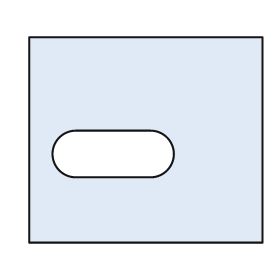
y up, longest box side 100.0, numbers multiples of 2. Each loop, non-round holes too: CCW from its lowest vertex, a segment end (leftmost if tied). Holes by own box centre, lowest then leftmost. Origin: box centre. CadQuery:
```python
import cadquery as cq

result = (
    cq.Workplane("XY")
    .moveTo(-50.0, -44.0)
    .lineTo(50.0, -44.0)
    .lineTo(50.0, 44.0)
    .lineTo(-50.0, 44.0)
    .close()
    .moveTo(-30.0, -16.0)
    .lineTo(2.0, -16.0)
    .threePointArc((12.0, -6.0), (2.0, 4.0))
    .lineTo(-30.0, 4.0)
    .threePointArc((-40.0, -6.0), (-30.0, -16.0))
    .close()
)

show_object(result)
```